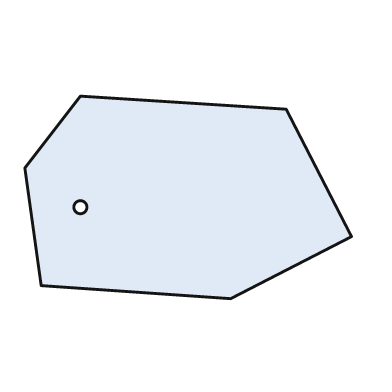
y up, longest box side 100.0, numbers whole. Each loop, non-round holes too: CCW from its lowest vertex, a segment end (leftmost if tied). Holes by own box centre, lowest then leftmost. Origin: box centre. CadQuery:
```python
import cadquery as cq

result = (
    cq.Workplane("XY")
    .moveTo(13.0, -31.0)
    .lineTo(50.0, -12.0)
    .lineTo(30.0, 27.0)
    .lineTo(-33.0, 31.0)
    .lineTo(-50.0, 9.0)
    .lineTo(-45.0, -27.0)
    .close()
    .moveTo(-33.0, -3.0)
    .circle(2.0)
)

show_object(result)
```